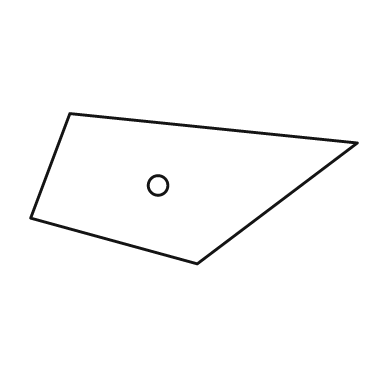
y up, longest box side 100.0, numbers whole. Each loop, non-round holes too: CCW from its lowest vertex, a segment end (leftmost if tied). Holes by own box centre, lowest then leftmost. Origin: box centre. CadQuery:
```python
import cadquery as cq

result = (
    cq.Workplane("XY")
    .moveTo(1.0, -23.0)
    .lineTo(50.0, 14.0)
    .lineTo(-38.0, 23.0)
    .lineTo(-50.0, -9.0)
    .close()
    .moveTo(-11.0, 1.0)
    .circle(3.0)
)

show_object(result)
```